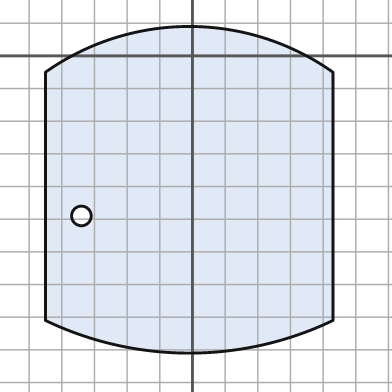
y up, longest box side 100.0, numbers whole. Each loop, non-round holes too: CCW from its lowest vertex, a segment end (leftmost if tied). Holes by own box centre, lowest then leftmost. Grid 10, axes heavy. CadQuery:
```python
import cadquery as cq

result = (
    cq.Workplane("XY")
    .moveTo(-45.0, -81.0)
    .threePointArc((-1.0, -91.0), (43.0, -81.0))
    .lineTo(43.0, -5.0)
    .threePointArc((-1.0, 9.0), (-45.0, -5.0))
    .close()
    .moveTo(-34.0, -49.0)
    .circle(3.0)
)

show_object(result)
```